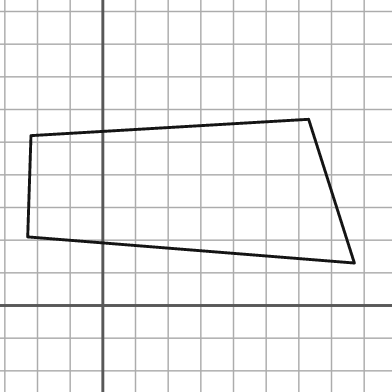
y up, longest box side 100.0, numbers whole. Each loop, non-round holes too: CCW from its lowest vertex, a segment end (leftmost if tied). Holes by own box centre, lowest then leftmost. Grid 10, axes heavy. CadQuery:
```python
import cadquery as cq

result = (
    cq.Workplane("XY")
    .moveTo(77.0, 13.0)
    .lineTo(63.0, 57.0)
    .lineTo(-22.0, 52.0)
    .lineTo(-23.0, 21.0)
    .close()
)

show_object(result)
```